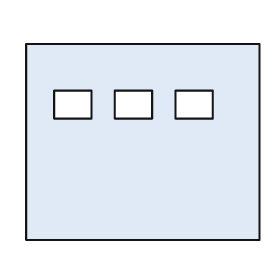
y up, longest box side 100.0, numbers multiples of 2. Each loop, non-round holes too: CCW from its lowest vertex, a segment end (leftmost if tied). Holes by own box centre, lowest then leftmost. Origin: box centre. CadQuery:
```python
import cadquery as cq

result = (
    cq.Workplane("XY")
    .moveTo(-50.0, -42.0)
    .lineTo(50.0, -42.0)
    .lineTo(50.0, 42.0)
    .lineTo(-50.0, 42.0)
    .close()
    .moveTo(-38.0, 10.0)
    .lineTo(-22.0, 10.0)
    .lineTo(-22.0, 22.0)
    .lineTo(-38.0, 22.0)
    .close()
    .moveTo(-12.0, 10.0)
    .lineTo(4.0, 10.0)
    .lineTo(4.0, 22.0)
    .lineTo(-12.0, 22.0)
    .close()
    .moveTo(14.0, 10.0)
    .lineTo(30.0, 10.0)
    .lineTo(30.0, 22.0)
    .lineTo(14.0, 22.0)
    .close()
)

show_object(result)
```